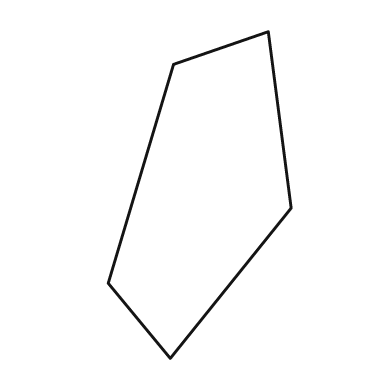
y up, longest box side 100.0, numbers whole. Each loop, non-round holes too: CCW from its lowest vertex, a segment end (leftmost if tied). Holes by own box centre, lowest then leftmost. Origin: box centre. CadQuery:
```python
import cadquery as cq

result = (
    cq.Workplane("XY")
    .moveTo(-9.0, -50.0)
    .lineTo(28.0, -4.0)
    .lineTo(21.0, 50.0)
    .lineTo(-8.0, 40.0)
    .lineTo(-28.0, -27.0)
    .close()
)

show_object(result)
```